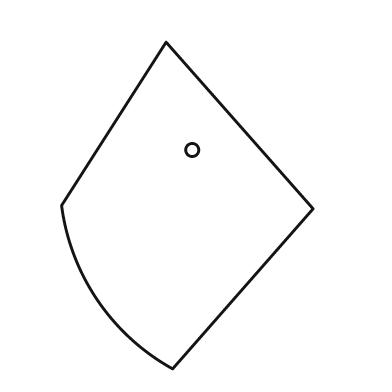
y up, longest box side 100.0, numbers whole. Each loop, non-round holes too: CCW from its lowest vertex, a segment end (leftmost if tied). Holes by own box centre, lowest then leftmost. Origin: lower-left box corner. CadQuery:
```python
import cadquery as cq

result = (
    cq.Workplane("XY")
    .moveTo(34.0, 0.0)
    .lineTo(77.0, 49.0)
    .lineTo(32.0, 100.0)
    .lineTo(0.0, 50.0)
    .threePointArc((11.0, 21.0), (34.0, 0.0))
    .close()
    .moveTo(40.0, 67.0)
    .circle(2.0)
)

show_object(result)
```